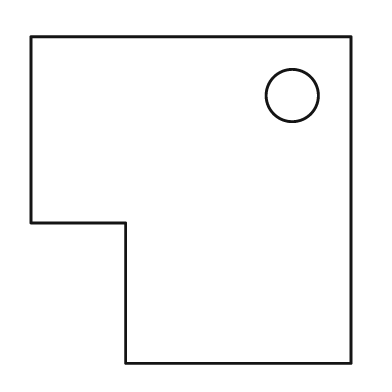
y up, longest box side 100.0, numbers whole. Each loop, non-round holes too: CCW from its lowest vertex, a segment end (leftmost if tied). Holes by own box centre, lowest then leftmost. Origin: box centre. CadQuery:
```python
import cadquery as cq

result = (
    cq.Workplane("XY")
    .moveTo(-20.0, -50.0)
    .lineTo(49.0, -50.0)
    .lineTo(49.0, 50.0)
    .lineTo(-49.0, 50.0)
    .lineTo(-49.0, -7.0)
    .lineTo(-20.0, -7.0)
    .close()
    .moveTo(31.0, 32.0)
    .circle(8.0)
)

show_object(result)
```